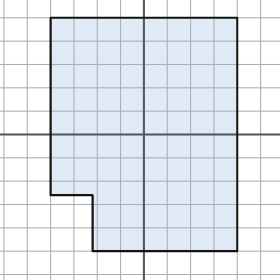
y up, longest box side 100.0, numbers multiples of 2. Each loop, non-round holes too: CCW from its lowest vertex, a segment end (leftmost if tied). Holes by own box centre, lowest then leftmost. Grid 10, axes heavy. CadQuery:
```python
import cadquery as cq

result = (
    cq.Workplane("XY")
    .moveTo(-22.0, -50.0)
    .lineTo(40.0, -50.0)
    .lineTo(40.0, 50.0)
    .lineTo(-40.0, 50.0)
    .lineTo(-40.0, -26.0)
    .lineTo(-22.0, -26.0)
    .close()
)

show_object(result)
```